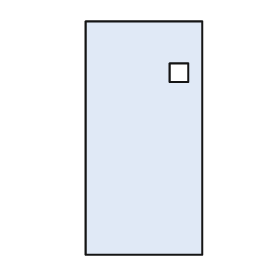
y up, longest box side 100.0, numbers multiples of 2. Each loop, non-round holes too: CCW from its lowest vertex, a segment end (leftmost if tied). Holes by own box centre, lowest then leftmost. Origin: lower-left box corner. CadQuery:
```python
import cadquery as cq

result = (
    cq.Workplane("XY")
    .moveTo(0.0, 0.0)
    .lineTo(50.0, 0.0)
    .lineTo(50.0, 100.0)
    .lineTo(0.0, 100.0)
    .close()
    .moveTo(36.0, 74.0)
    .lineTo(44.0, 74.0)
    .lineTo(44.0, 82.0)
    .lineTo(36.0, 82.0)
    .close()
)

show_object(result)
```